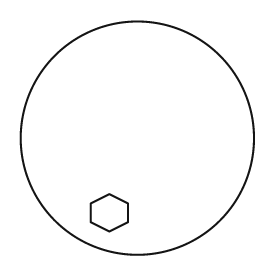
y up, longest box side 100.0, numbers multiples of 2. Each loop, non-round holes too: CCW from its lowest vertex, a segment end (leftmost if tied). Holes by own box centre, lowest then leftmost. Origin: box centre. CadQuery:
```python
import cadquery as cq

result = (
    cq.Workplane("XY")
    .moveTo(0.0, 0.0)
    .circle(50.0)
    .moveTo(-12.0, -40.0)
    .lineTo(-4.0, -36.0)
    .lineTo(-4.0, -28.0)
    .lineTo(-12.0, -24.0)
    .lineTo(-20.0, -28.0)
    .lineTo(-20.0, -36.0)
    .close()
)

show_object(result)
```